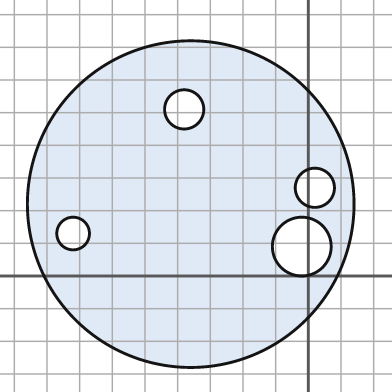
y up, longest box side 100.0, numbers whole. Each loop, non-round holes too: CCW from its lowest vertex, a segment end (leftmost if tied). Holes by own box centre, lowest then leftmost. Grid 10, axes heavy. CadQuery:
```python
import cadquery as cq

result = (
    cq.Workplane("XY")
    .moveTo(-36.0, 22.0)
    .circle(50.0)
    .moveTo(-2.0, 9.0)
    .circle(9.0)
    .moveTo(-72.0, 13.0)
    .circle(5.0)
    .moveTo(2.0, 27.0)
    .circle(6.0)
    .moveTo(-38.0, 51.0)
    .circle(6.0)
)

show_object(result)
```